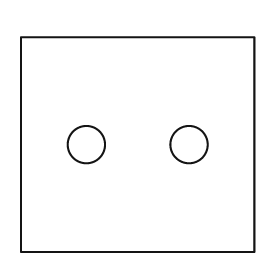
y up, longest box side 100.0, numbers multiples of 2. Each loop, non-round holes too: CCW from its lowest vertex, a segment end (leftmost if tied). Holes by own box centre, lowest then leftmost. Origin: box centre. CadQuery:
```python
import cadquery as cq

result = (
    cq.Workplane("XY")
    .moveTo(-50.0, -46.0)
    .lineTo(50.0, -46.0)
    .lineTo(50.0, 46.0)
    .lineTo(-50.0, 46.0)
    .close()
    .moveTo(-22.0, 0.0)
    .circle(8.0)
    .moveTo(22.0, 0.0)
    .circle(8.0)
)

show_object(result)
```